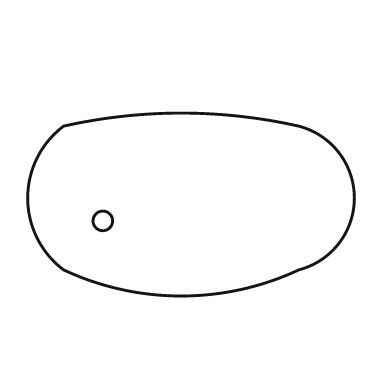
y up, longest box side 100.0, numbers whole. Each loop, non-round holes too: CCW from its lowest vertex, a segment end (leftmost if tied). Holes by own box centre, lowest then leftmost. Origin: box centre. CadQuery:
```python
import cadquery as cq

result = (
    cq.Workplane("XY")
    .moveTo(-39.0, -20.0)
    .threePointArc((-3.0, -28.0), (33.0, -20.0))
    .threePointArc((50.0, 2.0), (33.0, 24.0))
    .threePointArc((-3.0, 28.0), (-39.0, 24.0))
    .threePointArc((-50.0, 2.0), (-39.0, -20.0))
    .close()
    .moveTo(-27.0, -5.0)
    .circle(3.0)
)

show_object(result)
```